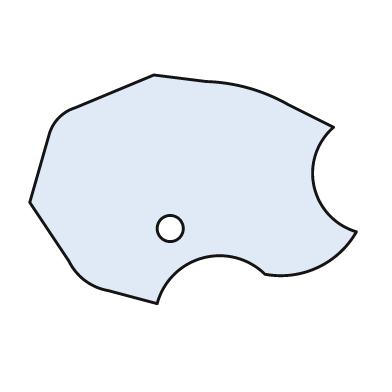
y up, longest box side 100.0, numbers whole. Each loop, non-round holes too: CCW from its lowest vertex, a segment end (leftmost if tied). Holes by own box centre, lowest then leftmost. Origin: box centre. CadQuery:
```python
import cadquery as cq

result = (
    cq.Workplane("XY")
    .moveTo(-11.0, -35.0)
    .threePointArc((3.0, -21.0), (22.0, -26.0))
    .threePointArc((38.0, -24.0), (50.0, -13.0))
    .threePointArc((37.0, 1.0), (43.0, 19.0))
    .lineTo(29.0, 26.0)
    .threePointArc((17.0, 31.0), (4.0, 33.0))
    .lineTo(-12.0, 35.0)
    .lineTo(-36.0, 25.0)
    .threePointArc((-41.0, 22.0), (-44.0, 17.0))
    .lineTo(-50.0, -4.0)
    .lineTo(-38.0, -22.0)
    .threePointArc((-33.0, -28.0), (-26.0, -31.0))
    .close()
    .moveTo(-7.0, -12.0)
    .circle(4.0)
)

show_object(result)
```